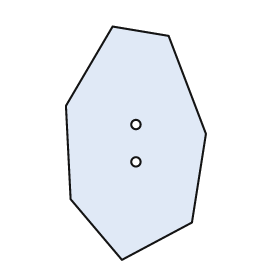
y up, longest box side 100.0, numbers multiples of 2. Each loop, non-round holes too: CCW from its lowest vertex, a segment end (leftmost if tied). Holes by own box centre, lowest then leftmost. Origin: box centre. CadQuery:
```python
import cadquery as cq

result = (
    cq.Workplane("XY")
    .moveTo(-6.0, -50.0)
    .lineTo(24.0, -34.0)
    .lineTo(30.0, 4.0)
    .lineTo(14.0, 46.0)
    .lineTo(-10.0, 50.0)
    .lineTo(-30.0, 16.0)
    .lineTo(-28.0, -24.0)
    .close()
    .moveTo(0.0, -8.0)
    .circle(2.0)
    .moveTo(0.0, 8.0)
    .circle(2.0)
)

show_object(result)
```